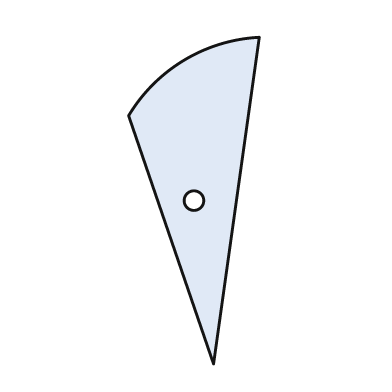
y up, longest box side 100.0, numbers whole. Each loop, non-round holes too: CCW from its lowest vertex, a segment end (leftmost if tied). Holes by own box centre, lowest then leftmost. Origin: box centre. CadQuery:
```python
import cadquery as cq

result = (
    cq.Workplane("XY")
    .moveTo(6.0, -50.0)
    .lineTo(20.0, 50.0)
    .threePointArc((-3.0, 43.0), (-20.0, 26.0))
    .close()
    .moveTo(0.0, 0.0)
    .circle(3.0)
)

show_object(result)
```